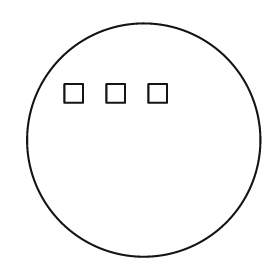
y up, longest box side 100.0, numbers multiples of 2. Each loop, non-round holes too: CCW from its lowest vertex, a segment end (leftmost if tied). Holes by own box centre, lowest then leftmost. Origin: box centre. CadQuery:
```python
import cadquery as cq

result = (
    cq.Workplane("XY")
    .moveTo(0.0, 0.0)
    .circle(50.0)
    .moveTo(-34.0, 16.0)
    .lineTo(-26.0, 16.0)
    .lineTo(-26.0, 24.0)
    .lineTo(-34.0, 24.0)
    .close()
    .moveTo(-16.0, 16.0)
    .lineTo(-8.0, 16.0)
    .lineTo(-8.0, 24.0)
    .lineTo(-16.0, 24.0)
    .close()
    .moveTo(2.0, 16.0)
    .lineTo(10.0, 16.0)
    .lineTo(10.0, 24.0)
    .lineTo(2.0, 24.0)
    .close()
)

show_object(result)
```